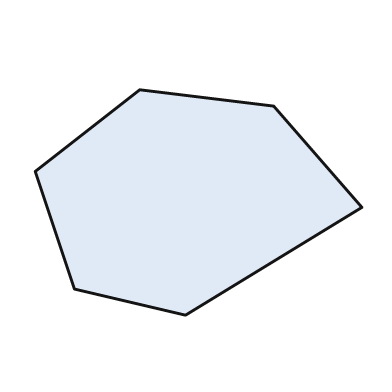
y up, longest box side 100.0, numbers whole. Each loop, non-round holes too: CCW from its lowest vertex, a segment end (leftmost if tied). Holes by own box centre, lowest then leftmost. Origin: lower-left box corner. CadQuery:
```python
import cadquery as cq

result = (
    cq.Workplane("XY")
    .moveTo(46.0, 0.0)
    .lineTo(100.0, 33.0)
    .lineTo(73.0, 64.0)
    .lineTo(32.0, 69.0)
    .lineTo(0.0, 44.0)
    .lineTo(12.0, 8.0)
    .close()
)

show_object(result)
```